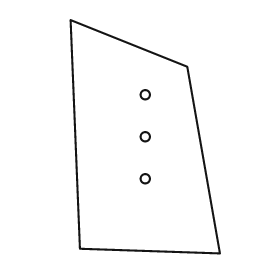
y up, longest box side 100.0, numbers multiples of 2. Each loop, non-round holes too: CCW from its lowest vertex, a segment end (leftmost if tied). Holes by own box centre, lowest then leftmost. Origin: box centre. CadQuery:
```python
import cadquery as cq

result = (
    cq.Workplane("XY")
    .moveTo(32.0, -50.0)
    .lineTo(18.0, 30.0)
    .lineTo(-32.0, 50.0)
    .lineTo(-28.0, -48.0)
    .close()
    .moveTo(0.0, -18.0)
    .circle(2.0)
    .moveTo(0.0, 0.0)
    .circle(2.0)
    .moveTo(0.0, 18.0)
    .circle(2.0)
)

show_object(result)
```